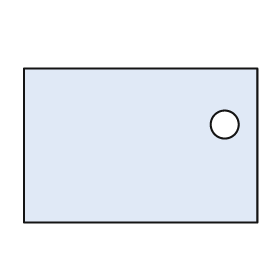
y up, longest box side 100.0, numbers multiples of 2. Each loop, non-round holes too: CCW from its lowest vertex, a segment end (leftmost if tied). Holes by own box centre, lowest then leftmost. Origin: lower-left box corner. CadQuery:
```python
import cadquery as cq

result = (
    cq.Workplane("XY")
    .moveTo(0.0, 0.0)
    .lineTo(100.0, 0.0)
    .lineTo(100.0, 66.0)
    .lineTo(0.0, 66.0)
    .close()
    .moveTo(86.0, 42.0)
    .circle(6.0)
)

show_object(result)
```